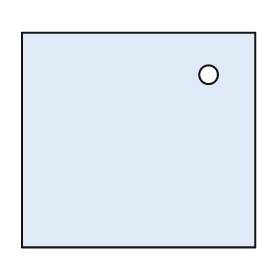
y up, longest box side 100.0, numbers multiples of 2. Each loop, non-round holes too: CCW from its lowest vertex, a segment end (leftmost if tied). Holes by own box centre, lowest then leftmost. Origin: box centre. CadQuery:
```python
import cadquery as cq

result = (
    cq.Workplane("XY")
    .moveTo(-50.0, -46.0)
    .lineTo(50.0, -46.0)
    .lineTo(50.0, 46.0)
    .lineTo(-50.0, 46.0)
    .close()
    .moveTo(30.0, 28.0)
    .circle(4.0)
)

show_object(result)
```